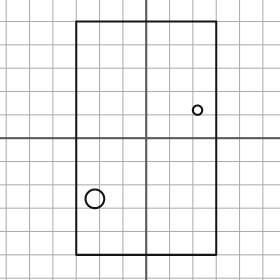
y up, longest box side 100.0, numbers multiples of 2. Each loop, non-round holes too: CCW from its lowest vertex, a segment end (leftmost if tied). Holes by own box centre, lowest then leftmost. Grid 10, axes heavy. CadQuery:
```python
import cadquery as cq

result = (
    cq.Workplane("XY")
    .moveTo(-30.0, -50.0)
    .lineTo(30.0, -50.0)
    .lineTo(30.0, 50.0)
    .lineTo(-30.0, 50.0)
    .close()
    .moveTo(-22.0, -26.0)
    .circle(4.0)
    .moveTo(22.0, 12.0)
    .circle(2.0)
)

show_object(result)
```